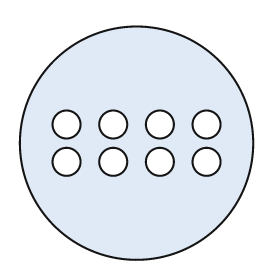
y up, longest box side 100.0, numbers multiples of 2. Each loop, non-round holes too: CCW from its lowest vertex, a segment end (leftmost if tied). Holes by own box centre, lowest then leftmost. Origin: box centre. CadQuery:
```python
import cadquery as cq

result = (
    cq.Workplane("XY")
    .moveTo(0.0, 0.0)
    .circle(50.0)
    .moveTo(-30.0, -8.0)
    .circle(6.0)
    .moveTo(-10.0, -8.0)
    .circle(6.0)
    .moveTo(10.0, -8.0)
    .circle(6.0)
    .moveTo(30.0, -8.0)
    .circle(6.0)
    .moveTo(-30.0, 8.0)
    .circle(6.0)
    .moveTo(-10.0, 8.0)
    .circle(6.0)
    .moveTo(10.0, 8.0)
    .circle(6.0)
    .moveTo(30.0, 8.0)
    .circle(6.0)
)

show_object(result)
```